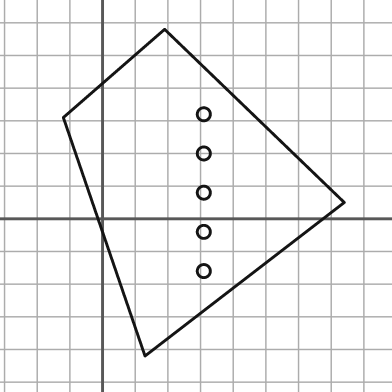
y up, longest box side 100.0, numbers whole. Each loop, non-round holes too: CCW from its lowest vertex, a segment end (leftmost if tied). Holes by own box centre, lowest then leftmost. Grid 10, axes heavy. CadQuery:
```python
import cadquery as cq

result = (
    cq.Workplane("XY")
    .moveTo(13.0, -42.0)
    .lineTo(74.0, 5.0)
    .lineTo(19.0, 58.0)
    .lineTo(-12.0, 31.0)
    .close()
    .moveTo(31.0, -16.0)
    .circle(2.0)
    .moveTo(31.0, -4.0)
    .circle(2.0)
    .moveTo(31.0, 8.0)
    .circle(2.0)
    .moveTo(31.0, 20.0)
    .circle(2.0)
    .moveTo(31.0, 32.0)
    .circle(2.0)
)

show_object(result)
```